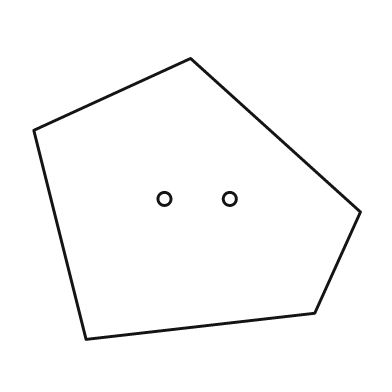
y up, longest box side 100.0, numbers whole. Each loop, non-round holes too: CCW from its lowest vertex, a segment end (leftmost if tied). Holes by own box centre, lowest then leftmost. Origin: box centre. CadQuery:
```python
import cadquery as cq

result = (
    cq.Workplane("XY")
    .moveTo(-34.0, -43.0)
    .lineTo(36.0, -35.0)
    .lineTo(50.0, -4.0)
    .lineTo(-2.0, 43.0)
    .lineTo(-50.0, 21.0)
    .close()
    .moveTo(-10.0, 0.0)
    .circle(2.0)
    .moveTo(10.0, 0.0)
    .circle(2.0)
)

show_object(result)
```